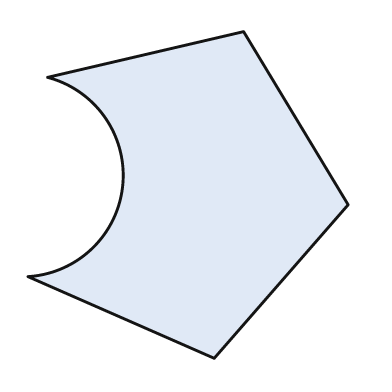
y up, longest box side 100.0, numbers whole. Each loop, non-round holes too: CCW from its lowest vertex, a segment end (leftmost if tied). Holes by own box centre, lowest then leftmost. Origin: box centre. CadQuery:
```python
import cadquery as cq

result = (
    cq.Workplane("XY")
    .moveTo(8.0, -50.0)
    .lineTo(49.0, -3.0)
    .lineTo(17.0, 50.0)
    .lineTo(-43.0, 36.0)
    .threePointArc((-20.0, 3.0), (-49.0, -25.0))
    .close()
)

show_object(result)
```